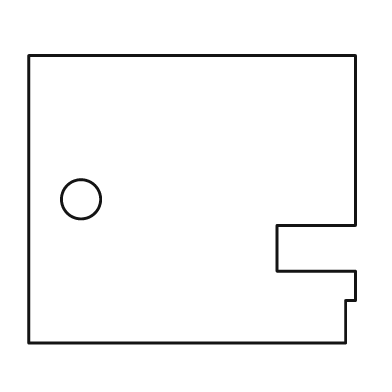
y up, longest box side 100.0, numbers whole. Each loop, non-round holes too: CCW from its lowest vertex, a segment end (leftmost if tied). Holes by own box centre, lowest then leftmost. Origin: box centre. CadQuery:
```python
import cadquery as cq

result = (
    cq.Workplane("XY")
    .moveTo(-50.0, -44.0)
    .lineTo(47.0, -44.0)
    .lineTo(47.0, -31.0)
    .lineTo(50.0, -31.0)
    .lineTo(50.0, -22.0)
    .lineTo(26.0, -22.0)
    .lineTo(26.0, -8.0)
    .lineTo(50.0, -8.0)
    .lineTo(50.0, 44.0)
    .lineTo(-50.0, 44.0)
    .close()
    .moveTo(-34.0, 0.0)
    .circle(6.0)
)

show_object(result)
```